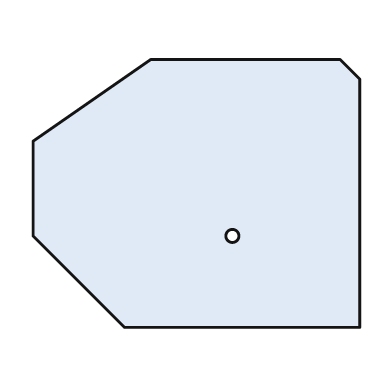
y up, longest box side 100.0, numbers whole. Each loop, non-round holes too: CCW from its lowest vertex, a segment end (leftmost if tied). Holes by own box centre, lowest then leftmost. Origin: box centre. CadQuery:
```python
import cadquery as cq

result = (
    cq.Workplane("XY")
    .moveTo(-22.0, -41.0)
    .lineTo(50.0, -41.0)
    .lineTo(50.0, 35.0)
    .lineTo(44.0, 41.0)
    .lineTo(-14.0, 41.0)
    .lineTo(-50.0, 16.0)
    .lineTo(-50.0, -13.0)
    .close()
    .moveTo(11.0, -13.0)
    .circle(2.0)
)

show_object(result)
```